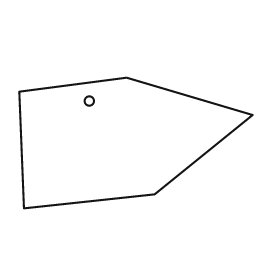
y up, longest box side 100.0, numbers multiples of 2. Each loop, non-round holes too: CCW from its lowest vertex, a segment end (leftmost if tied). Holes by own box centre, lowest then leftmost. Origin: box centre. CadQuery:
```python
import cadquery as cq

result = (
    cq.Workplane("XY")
    .moveTo(-48.0, -28.0)
    .lineTo(8.0, -22.0)
    .lineTo(50.0, 12.0)
    .lineTo(-4.0, 28.0)
    .lineTo(-50.0, 22.0)
    .close()
    .moveTo(-20.0, 18.0)
    .circle(2.0)
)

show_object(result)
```